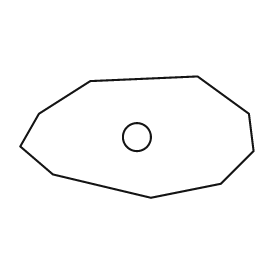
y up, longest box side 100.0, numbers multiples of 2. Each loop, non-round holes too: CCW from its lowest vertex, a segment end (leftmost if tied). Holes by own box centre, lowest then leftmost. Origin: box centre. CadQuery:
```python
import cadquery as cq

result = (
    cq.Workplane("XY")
    .moveTo(6.0, -26.0)
    .lineTo(36.0, -20.0)
    .lineTo(50.0, -6.0)
    .lineTo(48.0, 10.0)
    .lineTo(26.0, 26.0)
    .lineTo(-20.0, 24.0)
    .lineTo(-42.0, 10.0)
    .lineTo(-50.0, -4.0)
    .lineTo(-36.0, -16.0)
    .close()
    .moveTo(0.0, 0.0)
    .circle(6.0)
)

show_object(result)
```